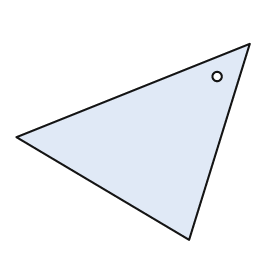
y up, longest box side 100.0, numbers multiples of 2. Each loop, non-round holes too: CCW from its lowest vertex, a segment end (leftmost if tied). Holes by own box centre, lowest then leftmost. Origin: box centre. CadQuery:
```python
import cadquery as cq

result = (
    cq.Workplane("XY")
    .moveTo(24.0, -42.0)
    .lineTo(50.0, 42.0)
    .lineTo(-50.0, 2.0)
    .close()
    .moveTo(36.0, 28.0)
    .circle(2.0)
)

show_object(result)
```